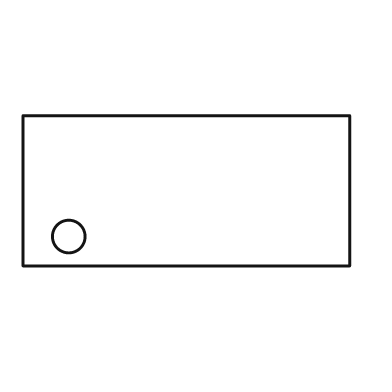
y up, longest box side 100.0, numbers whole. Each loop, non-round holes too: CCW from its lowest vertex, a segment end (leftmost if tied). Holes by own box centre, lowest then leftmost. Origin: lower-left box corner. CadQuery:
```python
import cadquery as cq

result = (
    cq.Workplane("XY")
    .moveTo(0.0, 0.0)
    .lineTo(100.0, 0.0)
    .lineTo(100.0, 46.0)
    .lineTo(0.0, 46.0)
    .close()
    .moveTo(14.0, 9.0)
    .circle(5.0)
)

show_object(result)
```